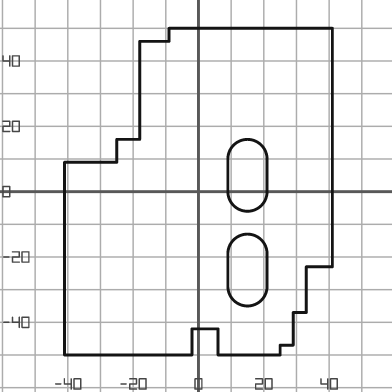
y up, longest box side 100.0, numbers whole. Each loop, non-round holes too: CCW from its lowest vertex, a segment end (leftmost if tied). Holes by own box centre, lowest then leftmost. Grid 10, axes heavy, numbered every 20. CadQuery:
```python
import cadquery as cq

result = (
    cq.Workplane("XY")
    .moveTo(-41.0, -50.0)
    .lineTo(-2.0, -50.0)
    .lineTo(-2.0, -42.0)
    .lineTo(6.0, -42.0)
    .lineTo(6.0, -50.0)
    .lineTo(25.0, -50.0)
    .lineTo(25.0, -47.0)
    .lineTo(29.0, -47.0)
    .lineTo(29.0, -37.0)
    .lineTo(33.0, -37.0)
    .lineTo(33.0, -23.0)
    .lineTo(41.0, -23.0)
    .lineTo(41.0, 50.0)
    .lineTo(-9.0, 50.0)
    .lineTo(-9.0, 46.0)
    .lineTo(-18.0, 46.0)
    .lineTo(-18.0, 16.0)
    .lineTo(-25.0, 16.0)
    .lineTo(-25.0, 9.0)
    .lineTo(-41.0, 9.0)
    .close()
    .moveTo(9.0, -29.0)
    .threePointArc((15.0, -35.0), (21.0, -29.0))
    .lineTo(21.0, -19.0)
    .threePointArc((15.0, -13.0), (9.0, -19.0))
    .close()
    .moveTo(9.0, 0.0)
    .threePointArc((15.0, -6.0), (21.0, 0.0))
    .lineTo(21.0, 10.0)
    .threePointArc((15.0, 16.0), (9.0, 10.0))
    .close()
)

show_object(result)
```